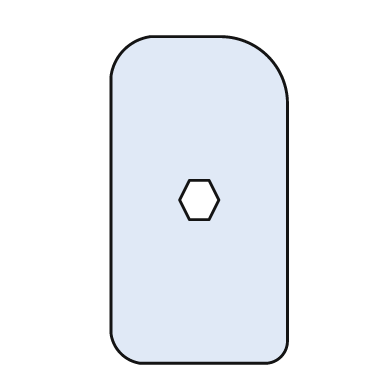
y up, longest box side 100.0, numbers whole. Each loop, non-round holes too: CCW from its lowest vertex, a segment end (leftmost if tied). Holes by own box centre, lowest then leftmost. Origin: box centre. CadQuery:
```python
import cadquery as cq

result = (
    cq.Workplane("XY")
    .moveTo(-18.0, -50.0)
    .lineTo(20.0, -50.0)
    .threePointArc((25.0, -48.0), (27.0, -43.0))
    .lineTo(27.0, 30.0)
    .threePointArc((21.0, 44.0), (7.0, 50.0))
    .lineTo(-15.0, 50.0)
    .threePointArc((-23.0, 46.0), (-27.0, 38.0))
    .lineTo(-27.0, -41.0)
    .threePointArc((-24.0, -47.0), (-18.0, -50.0))
    .close()
    .moveTo(-3.0, -6.0)
    .lineTo(3.0, -6.0)
    .lineTo(6.0, 0.0)
    .lineTo(3.0, 6.0)
    .lineTo(-3.0, 6.0)
    .lineTo(-6.0, 0.0)
    .close()
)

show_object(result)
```